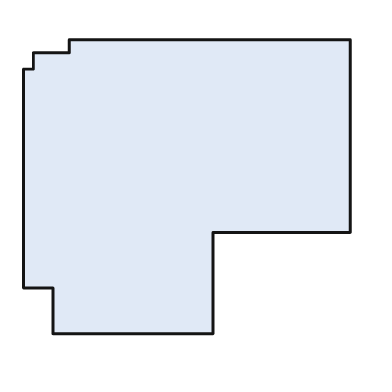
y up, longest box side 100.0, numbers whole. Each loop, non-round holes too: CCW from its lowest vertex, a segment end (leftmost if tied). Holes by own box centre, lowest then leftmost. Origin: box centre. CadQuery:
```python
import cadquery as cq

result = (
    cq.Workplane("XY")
    .moveTo(-41.0, -45.0)
    .lineTo(8.0, -45.0)
    .lineTo(8.0, -14.0)
    .lineTo(50.0, -14.0)
    .lineTo(50.0, 45.0)
    .lineTo(-36.0, 45.0)
    .lineTo(-36.0, 41.0)
    .lineTo(-47.0, 41.0)
    .lineTo(-47.0, 36.0)
    .lineTo(-50.0, 36.0)
    .lineTo(-50.0, -31.0)
    .lineTo(-41.0, -31.0)
    .close()
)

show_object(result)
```